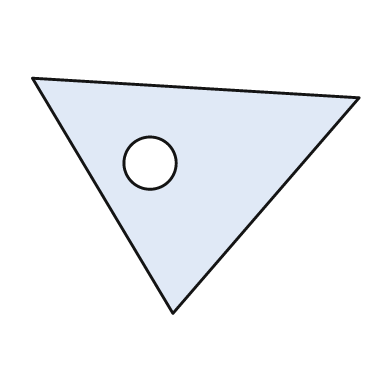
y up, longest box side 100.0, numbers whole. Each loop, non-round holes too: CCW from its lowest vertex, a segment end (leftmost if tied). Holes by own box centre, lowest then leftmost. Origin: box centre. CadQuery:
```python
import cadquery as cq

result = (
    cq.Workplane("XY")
    .moveTo(-7.0, -36.0)
    .lineTo(50.0, 30.0)
    .lineTo(-50.0, 36.0)
    .close()
    .moveTo(-14.0, 10.0)
    .circle(8.0)
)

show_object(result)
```